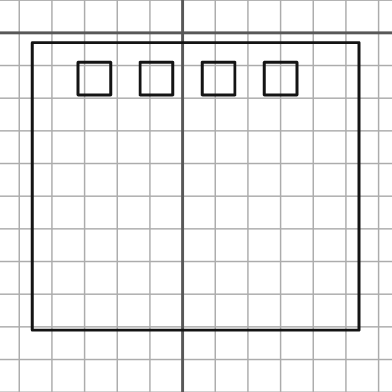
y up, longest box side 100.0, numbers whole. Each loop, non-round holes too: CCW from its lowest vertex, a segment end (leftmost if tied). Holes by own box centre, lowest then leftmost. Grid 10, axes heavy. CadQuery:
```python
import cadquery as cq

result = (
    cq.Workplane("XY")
    .moveTo(-46.0, -91.0)
    .lineTo(54.0, -91.0)
    .lineTo(54.0, -3.0)
    .lineTo(-46.0, -3.0)
    .close()
    .moveTo(-32.0, -19.0)
    .lineTo(-22.0, -19.0)
    .lineTo(-22.0, -9.0)
    .lineTo(-32.0, -9.0)
    .close()
    .moveTo(-13.0, -19.0)
    .lineTo(-3.0, -19.0)
    .lineTo(-3.0, -9.0)
    .lineTo(-13.0, -9.0)
    .close()
    .moveTo(6.0, -19.0)
    .lineTo(16.0, -19.0)
    .lineTo(16.0, -9.0)
    .lineTo(6.0, -9.0)
    .close()
    .moveTo(25.0, -19.0)
    .lineTo(35.0, -19.0)
    .lineTo(35.0, -9.0)
    .lineTo(25.0, -9.0)
    .close()
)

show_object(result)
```